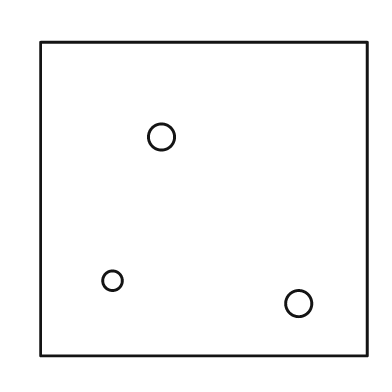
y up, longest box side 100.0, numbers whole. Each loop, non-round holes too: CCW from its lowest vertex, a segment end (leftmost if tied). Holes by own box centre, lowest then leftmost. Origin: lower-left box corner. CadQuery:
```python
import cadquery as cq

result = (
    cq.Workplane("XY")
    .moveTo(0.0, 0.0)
    .lineTo(100.0, 0.0)
    .lineTo(100.0, 96.0)
    .lineTo(0.0, 96.0)
    .close()
    .moveTo(79.0, 16.0)
    .circle(4.0)
    .moveTo(22.0, 23.0)
    .circle(3.0)
    .moveTo(37.0, 67.0)
    .circle(4.0)
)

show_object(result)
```